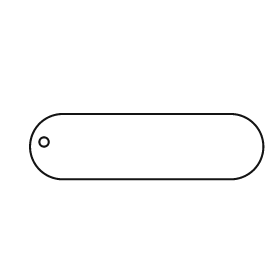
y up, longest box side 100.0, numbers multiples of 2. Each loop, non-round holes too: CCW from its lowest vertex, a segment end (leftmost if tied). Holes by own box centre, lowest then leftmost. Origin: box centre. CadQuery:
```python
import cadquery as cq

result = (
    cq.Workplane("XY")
    .moveTo(-36.0, -14.0)
    .lineTo(36.0, -14.0)
    .threePointArc((50.0, 0.0), (36.0, 14.0))
    .lineTo(-36.0, 14.0)
    .threePointArc((-50.0, 0.0), (-36.0, -14.0))
    .close()
    .moveTo(-44.0, 2.0)
    .circle(2.0)
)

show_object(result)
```